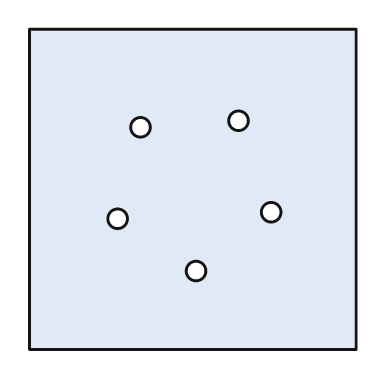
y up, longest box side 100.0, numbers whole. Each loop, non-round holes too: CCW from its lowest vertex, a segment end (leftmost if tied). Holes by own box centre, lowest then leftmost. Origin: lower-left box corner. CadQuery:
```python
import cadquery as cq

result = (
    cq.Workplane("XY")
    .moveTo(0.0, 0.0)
    .lineTo(100.0, 0.0)
    .lineTo(100.0, 98.0)
    .lineTo(0.0, 98.0)
    .close()
    .moveTo(51.0, 24.0)
    .circle(3.0)
    .moveTo(27.0, 40.0)
    .circle(3.0)
    .moveTo(74.0, 42.0)
    .circle(3.0)
    .moveTo(34.0, 68.0)
    .circle(3.0)
    .moveTo(64.0, 70.0)
    .circle(3.0)
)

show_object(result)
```